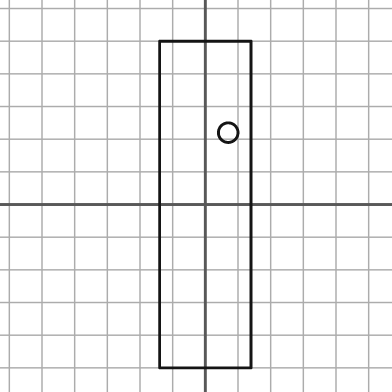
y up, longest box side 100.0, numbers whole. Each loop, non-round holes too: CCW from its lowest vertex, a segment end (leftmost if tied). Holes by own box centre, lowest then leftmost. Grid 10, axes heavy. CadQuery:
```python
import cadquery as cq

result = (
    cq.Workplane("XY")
    .moveTo(-14.0, -50.0)
    .lineTo(14.0, -50.0)
    .lineTo(14.0, 50.0)
    .lineTo(-14.0, 50.0)
    .close()
    .moveTo(7.0, 22.0)
    .circle(3.0)
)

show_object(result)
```